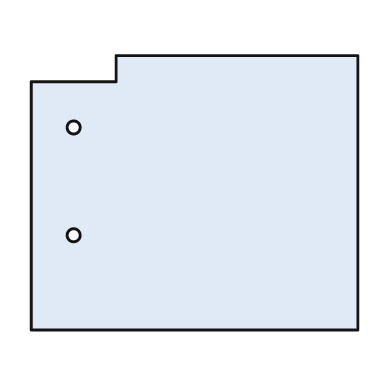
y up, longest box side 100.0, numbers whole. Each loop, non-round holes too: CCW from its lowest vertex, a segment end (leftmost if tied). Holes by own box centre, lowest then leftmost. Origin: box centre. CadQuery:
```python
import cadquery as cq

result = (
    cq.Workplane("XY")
    .moveTo(-50.0, -42.0)
    .lineTo(50.0, -42.0)
    .lineTo(50.0, 42.0)
    .lineTo(-24.0, 42.0)
    .lineTo(-24.0, 34.0)
    .lineTo(-50.0, 34.0)
    .close()
    .moveTo(-37.0, -13.0)
    .circle(2.0)
    .moveTo(-37.0, 20.0)
    .circle(2.0)
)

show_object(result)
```